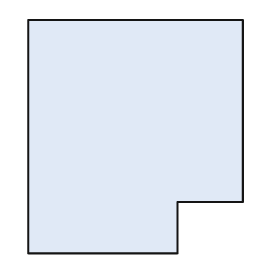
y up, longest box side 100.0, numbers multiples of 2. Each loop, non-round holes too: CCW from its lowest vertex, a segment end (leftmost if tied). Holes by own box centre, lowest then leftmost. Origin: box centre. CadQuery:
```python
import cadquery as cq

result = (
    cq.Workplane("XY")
    .moveTo(-46.0, -50.0)
    .lineTo(18.0, -50.0)
    .lineTo(18.0, -28.0)
    .lineTo(46.0, -28.0)
    .lineTo(46.0, 50.0)
    .lineTo(-46.0, 50.0)
    .close()
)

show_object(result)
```